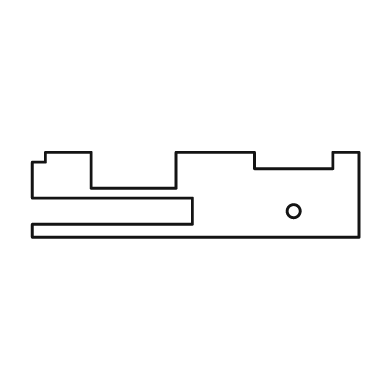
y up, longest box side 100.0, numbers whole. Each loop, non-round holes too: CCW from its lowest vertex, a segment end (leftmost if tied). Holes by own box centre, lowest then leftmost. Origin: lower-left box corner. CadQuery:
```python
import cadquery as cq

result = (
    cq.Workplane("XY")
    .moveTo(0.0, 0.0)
    .lineTo(100.0, 0.0)
    .lineTo(100.0, 26.0)
    .lineTo(92.0, 26.0)
    .lineTo(92.0, 21.0)
    .lineTo(68.0, 21.0)
    .lineTo(68.0, 26.0)
    .lineTo(44.0, 26.0)
    .lineTo(44.0, 15.0)
    .lineTo(18.0, 15.0)
    .lineTo(18.0, 26.0)
    .lineTo(4.0, 26.0)
    .lineTo(4.0, 23.0)
    .lineTo(0.0, 23.0)
    .lineTo(0.0, 12.0)
    .lineTo(49.0, 12.0)
    .lineTo(49.0, 4.0)
    .lineTo(0.0, 4.0)
    .close()
    .moveTo(80.0, 8.0)
    .circle(2.0)
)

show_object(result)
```